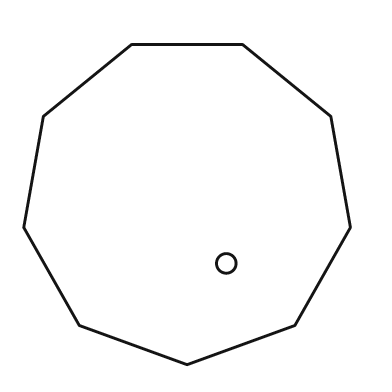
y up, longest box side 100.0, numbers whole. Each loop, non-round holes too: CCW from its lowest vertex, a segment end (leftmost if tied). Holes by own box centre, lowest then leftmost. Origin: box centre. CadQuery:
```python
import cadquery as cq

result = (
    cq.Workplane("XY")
    .moveTo(0.0, -49.0)
    .lineTo(33.0, -37.0)
    .lineTo(50.0, -7.0)
    .lineTo(44.0, 27.0)
    .lineTo(17.0, 49.0)
    .lineTo(-17.0, 49.0)
    .lineTo(-44.0, 27.0)
    .lineTo(-50.0, -7.0)
    .lineTo(-33.0, -37.0)
    .close()
    .moveTo(12.0, -18.0)
    .circle(3.0)
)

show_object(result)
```